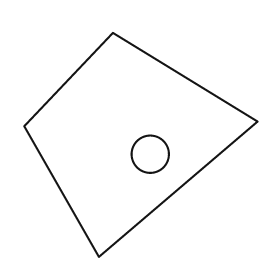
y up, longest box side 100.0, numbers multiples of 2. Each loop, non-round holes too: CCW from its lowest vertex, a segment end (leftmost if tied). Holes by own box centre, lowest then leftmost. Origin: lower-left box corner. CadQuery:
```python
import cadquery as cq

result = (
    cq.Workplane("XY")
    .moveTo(32.0, 0.0)
    .lineTo(100.0, 58.0)
    .lineTo(38.0, 96.0)
    .lineTo(0.0, 56.0)
    .close()
    .moveTo(54.0, 44.0)
    .circle(8.0)
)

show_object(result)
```